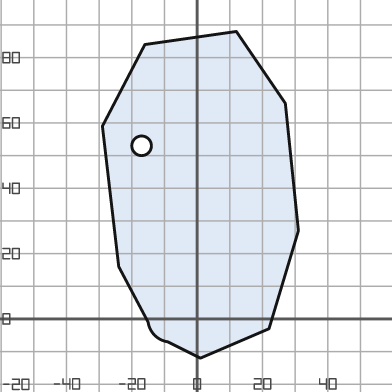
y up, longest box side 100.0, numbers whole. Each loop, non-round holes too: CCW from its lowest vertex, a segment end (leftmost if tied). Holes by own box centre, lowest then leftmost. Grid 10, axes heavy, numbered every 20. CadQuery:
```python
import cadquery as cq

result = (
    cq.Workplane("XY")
    .moveTo(1.0, -12.0)
    .lineTo(22.0, -3.0)
    .lineTo(31.0, 27.0)
    .lineTo(27.0, 66.0)
    .lineTo(12.0, 88.0)
    .lineTo(-16.0, 84.0)
    .lineTo(-29.0, 59.0)
    .lineTo(-24.0, 16.0)
    .lineTo(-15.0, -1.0)
    .threePointArc((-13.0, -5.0), (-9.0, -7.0))
    .close()
    .moveTo(-17.0, 53.0)
    .circle(3.0)
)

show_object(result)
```